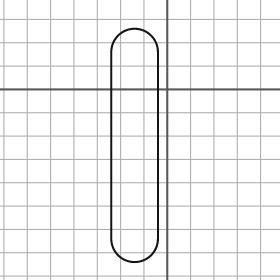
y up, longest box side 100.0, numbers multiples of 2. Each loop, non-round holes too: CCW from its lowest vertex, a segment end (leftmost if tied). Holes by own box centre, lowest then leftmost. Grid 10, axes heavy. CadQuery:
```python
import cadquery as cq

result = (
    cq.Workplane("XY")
    .moveTo(-24.0, -64.0)
    .threePointArc((-14.0, -74.0), (-4.0, -64.0))
    .lineTo(-4.0, 16.0)
    .threePointArc((-14.0, 26.0), (-24.0, 16.0))
    .close()
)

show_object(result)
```